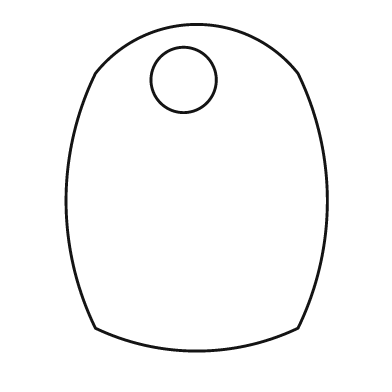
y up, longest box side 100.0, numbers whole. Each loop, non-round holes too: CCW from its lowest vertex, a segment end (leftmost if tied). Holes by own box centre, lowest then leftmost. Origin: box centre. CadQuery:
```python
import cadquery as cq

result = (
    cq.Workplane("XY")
    .moveTo(-31.0, -43.0)
    .threePointArc((0.0, -50.0), (31.0, -43.0))
    .threePointArc((40.0, -4.0), (31.0, 35.0))
    .threePointArc((0.0, 50.0), (-31.0, 35.0))
    .threePointArc((-40.0, -4.0), (-31.0, -43.0))
    .close()
    .moveTo(-4.0, 33.0)
    .circle(10.0)
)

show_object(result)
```